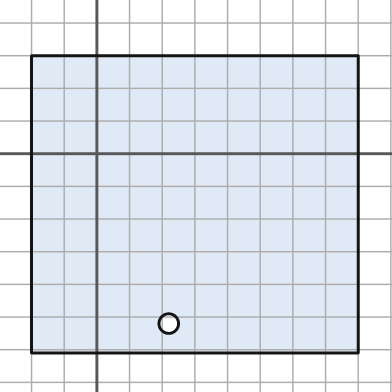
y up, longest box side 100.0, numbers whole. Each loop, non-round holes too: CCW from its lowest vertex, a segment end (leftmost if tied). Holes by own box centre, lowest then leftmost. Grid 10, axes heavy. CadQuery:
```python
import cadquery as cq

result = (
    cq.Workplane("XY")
    .moveTo(-20.0, -61.0)
    .lineTo(80.0, -61.0)
    .lineTo(80.0, 30.0)
    .lineTo(-20.0, 30.0)
    .close()
    .moveTo(22.0, -52.0)
    .circle(3.0)
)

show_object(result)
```